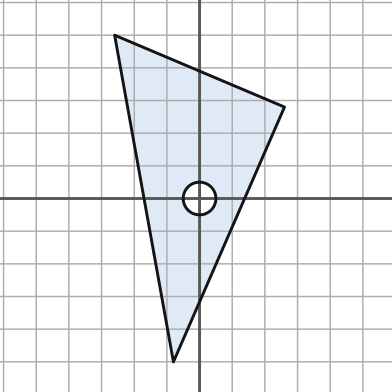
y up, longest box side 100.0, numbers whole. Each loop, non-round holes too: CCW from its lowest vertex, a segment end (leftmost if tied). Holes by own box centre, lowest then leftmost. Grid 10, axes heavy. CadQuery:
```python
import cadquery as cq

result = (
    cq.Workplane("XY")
    .moveTo(-8.0, -50.0)
    .lineTo(26.0, 28.0)
    .lineTo(-26.0, 50.0)
    .close()
    .moveTo(0.0, 0.0)
    .circle(5.0)
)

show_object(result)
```